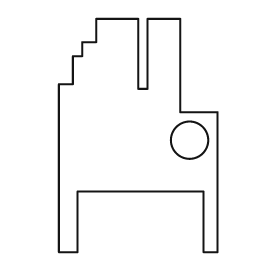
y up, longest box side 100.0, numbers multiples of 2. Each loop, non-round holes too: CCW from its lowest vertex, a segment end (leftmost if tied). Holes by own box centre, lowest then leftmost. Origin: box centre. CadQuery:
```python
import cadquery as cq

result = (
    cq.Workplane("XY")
    .moveTo(-34.0, -50.0)
    .lineTo(-26.0, -50.0)
    .lineTo(-26.0, -24.0)
    .lineTo(28.0, -24.0)
    .lineTo(28.0, -50.0)
    .lineTo(34.0, -50.0)
    .lineTo(34.0, 10.0)
    .lineTo(18.0, 10.0)
    .lineTo(18.0, 50.0)
    .lineTo(4.0, 50.0)
    .lineTo(4.0, 20.0)
    .lineTo(0.0, 20.0)
    .lineTo(0.0, 50.0)
    .lineTo(-18.0, 50.0)
    .lineTo(-18.0, 40.0)
    .lineTo(-24.0, 40.0)
    .lineTo(-24.0, 34.0)
    .lineTo(-28.0, 34.0)
    .lineTo(-28.0, 22.0)
    .lineTo(-34.0, 22.0)
    .close()
    .moveTo(22.0, -2.0)
    .circle(8.0)
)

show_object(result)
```